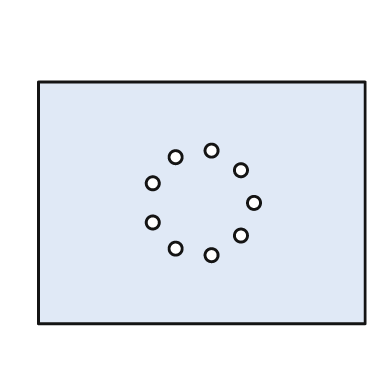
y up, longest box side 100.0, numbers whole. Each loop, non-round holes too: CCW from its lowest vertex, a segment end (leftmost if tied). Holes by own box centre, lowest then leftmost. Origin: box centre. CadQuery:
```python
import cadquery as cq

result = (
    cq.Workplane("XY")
    .moveTo(-50.0, -37.0)
    .lineTo(50.0, -37.0)
    .lineTo(50.0, 37.0)
    .lineTo(-50.0, 37.0)
    .close()
    .moveTo(3.0, -16.0)
    .circle(2.0)
    .moveTo(-8.0, -14.0)
    .circle(2.0)
    .moveTo(12.0, -10.0)
    .circle(2.0)
    .moveTo(-15.0, -6.0)
    .circle(2.0)
    .moveTo(16.0, 0.0)
    .circle(2.0)
    .moveTo(-15.0, 6.0)
    .circle(2.0)
    .moveTo(12.0, 10.0)
    .circle(2.0)
    .moveTo(-8.0, 14.0)
    .circle(2.0)
    .moveTo(3.0, 16.0)
    .circle(2.0)
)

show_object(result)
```